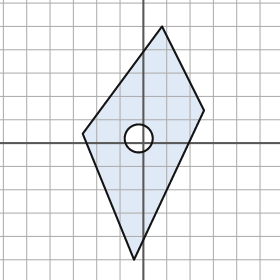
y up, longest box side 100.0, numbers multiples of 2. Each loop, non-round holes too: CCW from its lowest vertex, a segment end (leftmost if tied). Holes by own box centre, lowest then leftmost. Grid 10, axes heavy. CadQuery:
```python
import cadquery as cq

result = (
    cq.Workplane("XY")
    .moveTo(-4.0, -50.0)
    .lineTo(26.0, 14.0)
    .lineTo(8.0, 50.0)
    .lineTo(-26.0, 4.0)
    .close()
    .moveTo(-2.0, 2.0)
    .circle(6.0)
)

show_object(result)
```